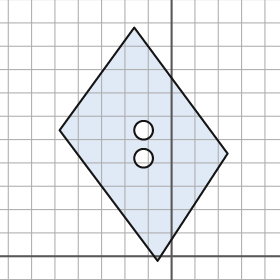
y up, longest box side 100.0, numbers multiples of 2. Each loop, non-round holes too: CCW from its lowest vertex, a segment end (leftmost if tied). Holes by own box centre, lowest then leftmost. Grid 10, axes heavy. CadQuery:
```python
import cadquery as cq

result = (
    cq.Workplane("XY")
    .moveTo(-6.0, -2.0)
    .lineTo(24.0, 44.0)
    .lineTo(-16.0, 98.0)
    .lineTo(-48.0, 54.0)
    .close()
    .moveTo(-12.0, 42.0)
    .circle(4.0)
    .moveTo(-12.0, 54.0)
    .circle(4.0)
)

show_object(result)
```